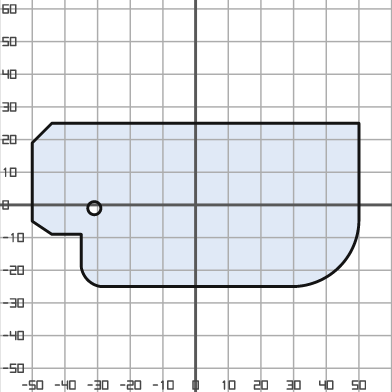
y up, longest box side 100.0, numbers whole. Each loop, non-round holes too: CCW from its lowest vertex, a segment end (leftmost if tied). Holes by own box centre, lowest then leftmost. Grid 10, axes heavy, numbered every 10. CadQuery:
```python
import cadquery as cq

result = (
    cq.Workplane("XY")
    .moveTo(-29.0, -25.0)
    .lineTo(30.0, -25.0)
    .threePointArc((44.0, -19.0), (50.0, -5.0))
    .lineTo(50.0, 25.0)
    .lineTo(-44.0, 25.0)
    .lineTo(-50.0, 19.0)
    .lineTo(-50.0, -5.0)
    .lineTo(-44.0, -9.0)
    .lineTo(-35.0, -9.0)
    .lineTo(-35.0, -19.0)
    .threePointArc((-33.0, -23.0), (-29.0, -25.0))
    .close()
    .moveTo(-31.0, -1.0)
    .circle(2.0)
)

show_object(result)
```